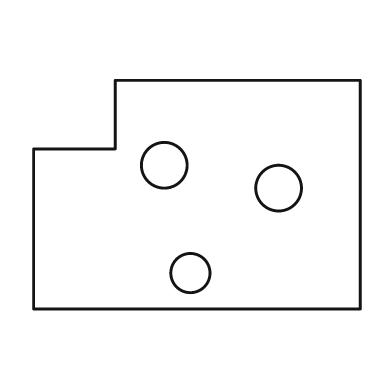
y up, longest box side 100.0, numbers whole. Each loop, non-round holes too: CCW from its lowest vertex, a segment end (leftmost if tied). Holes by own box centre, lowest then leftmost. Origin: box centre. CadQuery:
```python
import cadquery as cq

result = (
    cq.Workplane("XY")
    .moveTo(-50.0, -35.0)
    .lineTo(50.0, -35.0)
    .lineTo(50.0, 35.0)
    .lineTo(-25.0, 35.0)
    .lineTo(-25.0, 14.0)
    .lineTo(-50.0, 14.0)
    .close()
    .moveTo(-2.0, -24.0)
    .circle(6.0)
    .moveTo(25.0, 2.0)
    .circle(7.0)
    .moveTo(-10.0, 9.0)
    .circle(7.0)
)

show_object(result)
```